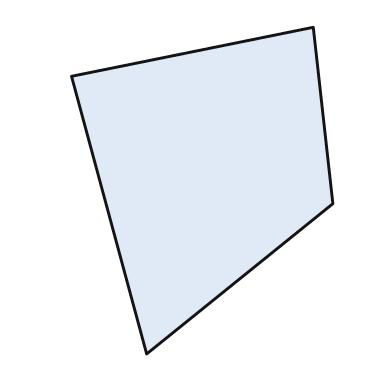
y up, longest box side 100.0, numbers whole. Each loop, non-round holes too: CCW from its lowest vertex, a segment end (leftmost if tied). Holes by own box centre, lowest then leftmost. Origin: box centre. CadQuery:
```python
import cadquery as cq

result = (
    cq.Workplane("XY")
    .moveTo(-17.0, -50.0)
    .lineTo(40.0, -4.0)
    .lineTo(34.0, 50.0)
    .lineTo(-40.0, 35.0)
    .close()
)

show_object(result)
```